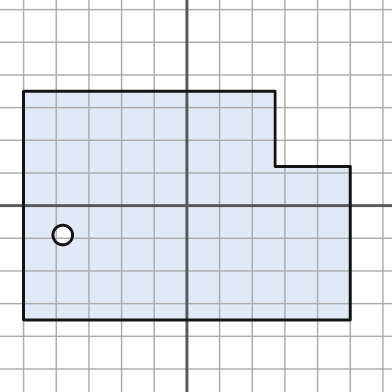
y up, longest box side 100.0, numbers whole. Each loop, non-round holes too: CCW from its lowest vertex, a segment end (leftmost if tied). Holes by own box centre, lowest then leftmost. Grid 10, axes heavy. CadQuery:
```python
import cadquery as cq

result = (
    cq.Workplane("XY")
    .moveTo(-50.0, -35.0)
    .lineTo(50.0, -35.0)
    .lineTo(50.0, 12.0)
    .lineTo(27.0, 12.0)
    .lineTo(27.0, 35.0)
    .lineTo(-50.0, 35.0)
    .close()
    .moveTo(-38.0, -9.0)
    .circle(3.0)
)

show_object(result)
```